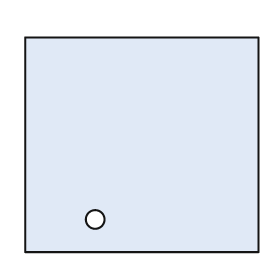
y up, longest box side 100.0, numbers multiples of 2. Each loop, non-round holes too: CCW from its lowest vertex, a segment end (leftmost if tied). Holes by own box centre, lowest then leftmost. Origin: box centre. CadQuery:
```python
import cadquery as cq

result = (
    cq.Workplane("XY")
    .moveTo(-50.0, -46.0)
    .lineTo(50.0, -46.0)
    .lineTo(50.0, 46.0)
    .lineTo(-50.0, 46.0)
    .close()
    .moveTo(-20.0, -32.0)
    .circle(4.0)
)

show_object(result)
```